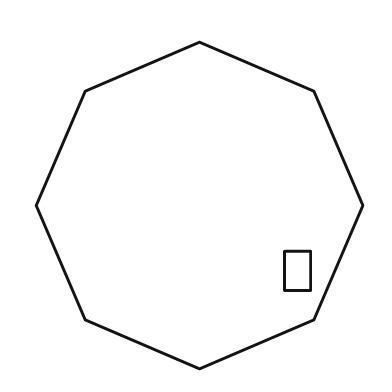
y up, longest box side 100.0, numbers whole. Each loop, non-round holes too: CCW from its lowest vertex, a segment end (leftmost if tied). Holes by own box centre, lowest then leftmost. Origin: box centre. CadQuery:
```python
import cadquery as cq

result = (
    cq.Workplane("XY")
    .moveTo(0.0, -50.0)
    .lineTo(35.0, -35.0)
    .lineTo(50.0, 0.0)
    .lineTo(35.0, 35.0)
    .lineTo(0.0, 50.0)
    .lineTo(-35.0, 35.0)
    .lineTo(-50.0, 0.0)
    .lineTo(-35.0, -35.0)
    .close()
    .moveTo(26.0, -26.0)
    .lineTo(34.0, -26.0)
    .lineTo(34.0, -14.0)
    .lineTo(26.0, -14.0)
    .close()
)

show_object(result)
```